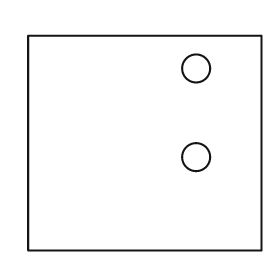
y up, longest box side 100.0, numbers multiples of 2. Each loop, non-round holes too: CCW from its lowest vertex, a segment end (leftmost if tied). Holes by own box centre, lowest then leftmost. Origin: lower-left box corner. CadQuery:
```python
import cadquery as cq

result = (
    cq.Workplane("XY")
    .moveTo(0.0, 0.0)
    .lineTo(100.0, 0.0)
    .lineTo(100.0, 92.0)
    .lineTo(0.0, 92.0)
    .close()
    .moveTo(72.0, 40.0)
    .circle(6.0)
    .moveTo(72.0, 78.0)
    .circle(6.0)
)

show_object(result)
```